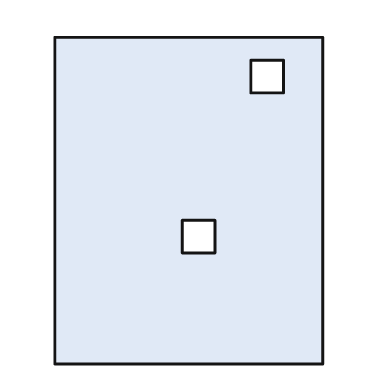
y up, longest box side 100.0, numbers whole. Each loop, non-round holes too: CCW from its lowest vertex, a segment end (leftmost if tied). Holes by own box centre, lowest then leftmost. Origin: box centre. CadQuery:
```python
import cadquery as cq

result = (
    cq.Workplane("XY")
    .moveTo(-41.0, -50.0)
    .lineTo(41.0, -50.0)
    .lineTo(41.0, 50.0)
    .lineTo(-41.0, 50.0)
    .close()
    .moveTo(-2.0, -16.0)
    .lineTo(8.0, -16.0)
    .lineTo(8.0, -6.0)
    .lineTo(-2.0, -6.0)
    .close()
    .moveTo(19.0, 33.0)
    .lineTo(29.0, 33.0)
    .lineTo(29.0, 43.0)
    .lineTo(19.0, 43.0)
    .close()
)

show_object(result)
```